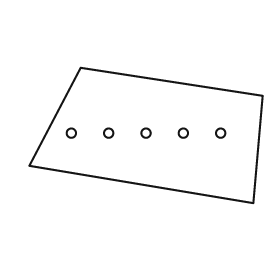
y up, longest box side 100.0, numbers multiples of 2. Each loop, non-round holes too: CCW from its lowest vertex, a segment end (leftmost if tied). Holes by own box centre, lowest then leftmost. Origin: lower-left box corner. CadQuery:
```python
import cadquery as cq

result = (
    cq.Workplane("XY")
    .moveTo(96.0, 0.0)
    .lineTo(100.0, 46.0)
    .lineTo(22.0, 58.0)
    .lineTo(0.0, 16.0)
    .close()
    .moveTo(18.0, 30.0)
    .circle(2.0)
    .moveTo(34.0, 30.0)
    .circle(2.0)
    .moveTo(50.0, 30.0)
    .circle(2.0)
    .moveTo(66.0, 30.0)
    .circle(2.0)
    .moveTo(82.0, 30.0)
    .circle(2.0)
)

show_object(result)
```